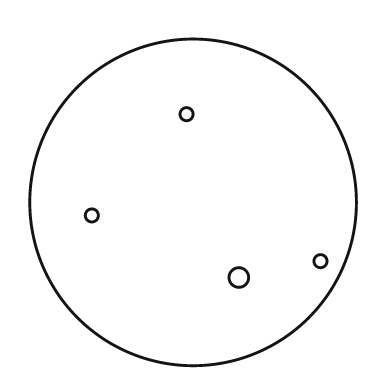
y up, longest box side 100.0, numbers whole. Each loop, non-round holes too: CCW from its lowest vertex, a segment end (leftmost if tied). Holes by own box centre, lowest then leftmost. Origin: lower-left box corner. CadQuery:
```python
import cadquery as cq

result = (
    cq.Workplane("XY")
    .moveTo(50.0, 50.0)
    .circle(50.0)
    .moveTo(64.0, 27.0)
    .circle(3.0)
    .moveTo(89.0, 32.0)
    .circle(2.0)
    .moveTo(19.0, 46.0)
    .circle(2.0)
    .moveTo(48.0, 77.0)
    .circle(2.0)
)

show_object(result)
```